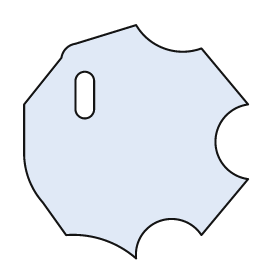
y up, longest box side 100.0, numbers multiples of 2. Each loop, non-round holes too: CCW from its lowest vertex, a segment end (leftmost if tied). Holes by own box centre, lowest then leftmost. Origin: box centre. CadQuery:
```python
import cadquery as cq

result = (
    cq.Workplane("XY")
    .moveTo(0.0, -50.0)
    .threePointArc((10.0, -34.0), (28.0, -40.0))
    .lineTo(48.0, -16.0)
    .threePointArc((34.0, 0.0), (48.0, 16.0))
    .lineTo(28.0, 40.0)
    .threePointArc((12.0, 40.0), (0.0, 50.0))
    .lineTo(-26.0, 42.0)
    .threePointArc((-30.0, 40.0), (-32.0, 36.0))
    .lineTo(-48.0, 16.0)
    .lineTo(-48.0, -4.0)
    .threePointArc((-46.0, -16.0), (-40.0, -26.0))
    .lineTo(-30.0, -40.0)
    .threePointArc((-14.0, -42.0), (0.0, -50.0))
    .close()
    .moveTo(-26.0, 14.0)
    .threePointArc((-22.0, 10.0), (-18.0, 14.0))
    .lineTo(-18.0, 26.0)
    .threePointArc((-22.0, 30.0), (-26.0, 26.0))
    .close()
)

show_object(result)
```